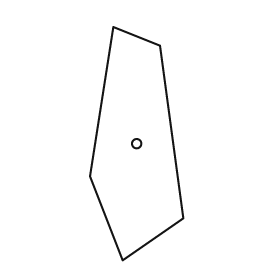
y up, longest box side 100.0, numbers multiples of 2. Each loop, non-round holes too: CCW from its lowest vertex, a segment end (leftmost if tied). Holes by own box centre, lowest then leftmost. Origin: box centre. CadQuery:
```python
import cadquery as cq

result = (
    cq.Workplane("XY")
    .moveTo(-6.0, -50.0)
    .lineTo(20.0, -32.0)
    .lineTo(10.0, 42.0)
    .lineTo(-10.0, 50.0)
    .lineTo(-20.0, -14.0)
    .close()
    .moveTo(0.0, 0.0)
    .circle(2.0)
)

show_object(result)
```